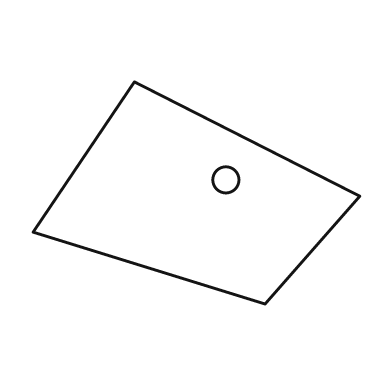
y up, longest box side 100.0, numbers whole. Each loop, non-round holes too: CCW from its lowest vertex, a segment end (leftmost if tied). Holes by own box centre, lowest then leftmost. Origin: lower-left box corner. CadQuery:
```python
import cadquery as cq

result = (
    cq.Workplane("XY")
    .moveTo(71.0, 0.0)
    .lineTo(100.0, 33.0)
    .lineTo(31.0, 68.0)
    .lineTo(0.0, 22.0)
    .close()
    .moveTo(59.0, 38.0)
    .circle(4.0)
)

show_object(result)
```